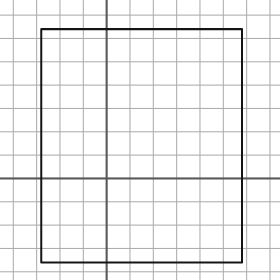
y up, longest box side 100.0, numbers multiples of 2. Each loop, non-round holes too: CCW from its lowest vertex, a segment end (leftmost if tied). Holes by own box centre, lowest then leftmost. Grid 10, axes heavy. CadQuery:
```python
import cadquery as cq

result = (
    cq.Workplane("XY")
    .moveTo(-28.0, -36.0)
    .lineTo(58.0, -36.0)
    .lineTo(58.0, 64.0)
    .lineTo(-28.0, 64.0)
    .close()
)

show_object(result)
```